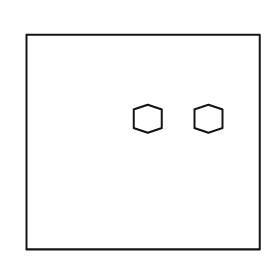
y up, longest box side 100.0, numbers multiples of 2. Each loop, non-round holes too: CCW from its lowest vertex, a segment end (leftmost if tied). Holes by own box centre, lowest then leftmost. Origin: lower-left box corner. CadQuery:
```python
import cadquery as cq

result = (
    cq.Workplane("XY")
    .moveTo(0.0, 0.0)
    .lineTo(100.0, 0.0)
    .lineTo(100.0, 92.0)
    .lineTo(0.0, 92.0)
    .close()
    .moveTo(52.0, 50.0)
    .lineTo(58.0, 52.0)
    .lineTo(58.0, 60.0)
    .lineTo(52.0, 62.0)
    .lineTo(46.0, 60.0)
    .lineTo(46.0, 52.0)
    .close()
    .moveTo(78.0, 50.0)
    .lineTo(84.0, 52.0)
    .lineTo(84.0, 60.0)
    .lineTo(78.0, 62.0)
    .lineTo(72.0, 60.0)
    .lineTo(72.0, 52.0)
    .close()
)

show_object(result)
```